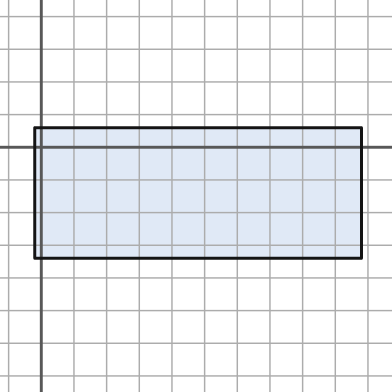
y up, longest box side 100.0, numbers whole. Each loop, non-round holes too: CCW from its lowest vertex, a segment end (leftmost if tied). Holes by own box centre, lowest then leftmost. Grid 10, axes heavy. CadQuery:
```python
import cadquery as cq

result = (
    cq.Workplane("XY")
    .moveTo(-2.0, -34.0)
    .lineTo(98.0, -34.0)
    .lineTo(98.0, 6.0)
    .lineTo(-2.0, 6.0)
    .close()
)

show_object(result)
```